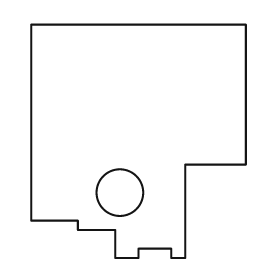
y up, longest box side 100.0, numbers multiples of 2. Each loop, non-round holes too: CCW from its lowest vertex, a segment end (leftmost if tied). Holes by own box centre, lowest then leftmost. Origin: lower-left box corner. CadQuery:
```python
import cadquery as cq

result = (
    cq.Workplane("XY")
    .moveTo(36.0, 0.0)
    .lineTo(46.0, 0.0)
    .lineTo(46.0, 4.0)
    .lineTo(60.0, 4.0)
    .lineTo(60.0, 0.0)
    .lineTo(66.0, 0.0)
    .lineTo(66.0, 40.0)
    .lineTo(92.0, 40.0)
    .lineTo(92.0, 100.0)
    .lineTo(0.0, 100.0)
    .lineTo(0.0, 16.0)
    .lineTo(20.0, 16.0)
    .lineTo(20.0, 12.0)
    .lineTo(36.0, 12.0)
    .close()
    .moveTo(38.0, 28.0)
    .circle(10.0)
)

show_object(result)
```